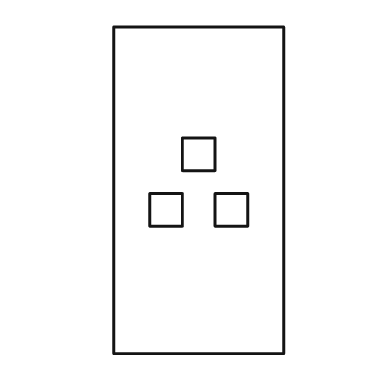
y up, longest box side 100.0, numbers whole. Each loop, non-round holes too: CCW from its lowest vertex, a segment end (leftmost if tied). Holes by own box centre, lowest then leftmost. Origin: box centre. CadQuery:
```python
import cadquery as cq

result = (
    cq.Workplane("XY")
    .moveTo(-26.0, -50.0)
    .lineTo(26.0, -50.0)
    .lineTo(26.0, 50.0)
    .lineTo(-26.0, 50.0)
    .close()
    .moveTo(-15.0, -11.0)
    .lineTo(-5.0, -11.0)
    .lineTo(-5.0, -1.0)
    .lineTo(-15.0, -1.0)
    .close()
    .moveTo(5.0, -11.0)
    .lineTo(15.0, -11.0)
    .lineTo(15.0, -1.0)
    .lineTo(5.0, -1.0)
    .close()
    .moveTo(-5.0, 6.0)
    .lineTo(5.0, 6.0)
    .lineTo(5.0, 16.0)
    .lineTo(-5.0, 16.0)
    .close()
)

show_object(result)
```